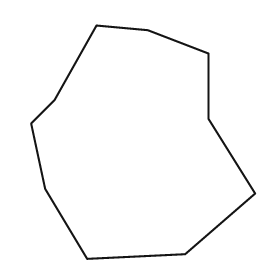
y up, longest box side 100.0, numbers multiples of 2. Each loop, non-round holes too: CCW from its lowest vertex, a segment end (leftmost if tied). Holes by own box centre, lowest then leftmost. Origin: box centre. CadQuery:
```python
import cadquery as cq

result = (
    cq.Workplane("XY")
    .moveTo(-24.0, -50.0)
    .lineTo(18.0, -48.0)
    .lineTo(48.0, -22.0)
    .lineTo(28.0, 10.0)
    .lineTo(28.0, 38.0)
    .lineTo(2.0, 48.0)
    .lineTo(-20.0, 50.0)
    .lineTo(-38.0, 18.0)
    .lineTo(-48.0, 8.0)
    .lineTo(-42.0, -20.0)
    .close()
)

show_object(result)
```